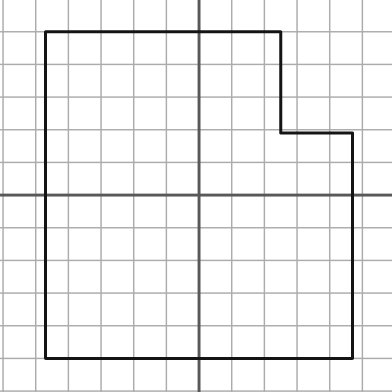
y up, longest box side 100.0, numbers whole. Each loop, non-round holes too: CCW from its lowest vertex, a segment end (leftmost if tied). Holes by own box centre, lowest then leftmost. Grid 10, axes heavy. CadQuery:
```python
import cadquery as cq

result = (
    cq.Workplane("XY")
    .moveTo(-47.0, -50.0)
    .lineTo(47.0, -50.0)
    .lineTo(47.0, 19.0)
    .lineTo(25.0, 19.0)
    .lineTo(25.0, 50.0)
    .lineTo(-47.0, 50.0)
    .close()
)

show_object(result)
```